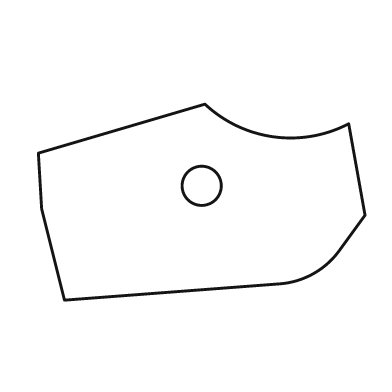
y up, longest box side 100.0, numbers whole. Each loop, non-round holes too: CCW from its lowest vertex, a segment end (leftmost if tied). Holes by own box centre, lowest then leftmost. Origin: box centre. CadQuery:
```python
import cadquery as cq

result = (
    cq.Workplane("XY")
    .moveTo(-42.0, -30.0)
    .lineTo(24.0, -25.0)
    .threePointArc((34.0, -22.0), (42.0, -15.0))
    .lineTo(50.0, -4.0)
    .lineTo(45.0, 24.0)
    .threePointArc((22.0, 20.0), (1.0, 30.0))
    .lineTo(-50.0, 15.0)
    .lineTo(-49.0, -2.0)
    .close()
    .moveTo(0.0, 5.0)
    .circle(6.0)
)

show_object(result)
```